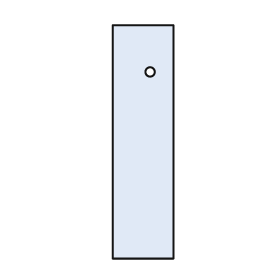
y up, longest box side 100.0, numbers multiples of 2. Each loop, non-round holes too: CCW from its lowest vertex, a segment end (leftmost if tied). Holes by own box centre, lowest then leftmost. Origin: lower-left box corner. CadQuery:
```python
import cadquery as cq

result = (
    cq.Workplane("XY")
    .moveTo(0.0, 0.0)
    .lineTo(26.0, 0.0)
    .lineTo(26.0, 100.0)
    .lineTo(0.0, 100.0)
    .close()
    .moveTo(16.0, 80.0)
    .circle(2.0)
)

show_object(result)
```